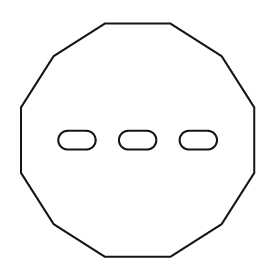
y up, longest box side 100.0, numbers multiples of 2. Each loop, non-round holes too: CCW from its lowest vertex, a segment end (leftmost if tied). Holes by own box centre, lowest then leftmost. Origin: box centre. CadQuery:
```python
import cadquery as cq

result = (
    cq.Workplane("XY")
    .moveTo(-14.0, -50.0)
    .lineTo(14.0, -50.0)
    .lineTo(36.0, -36.0)
    .lineTo(50.0, -14.0)
    .lineTo(50.0, 14.0)
    .lineTo(36.0, 36.0)
    .lineTo(14.0, 50.0)
    .lineTo(-14.0, 50.0)
    .lineTo(-36.0, 36.0)
    .lineTo(-50.0, 14.0)
    .lineTo(-50.0, -14.0)
    .lineTo(-36.0, -36.0)
    .close()
    .moveTo(-30.0, -4.0)
    .lineTo(-22.0, -4.0)
    .threePointArc((-18.0, 0.0), (-22.0, 4.0))
    .lineTo(-30.0, 4.0)
    .threePointArc((-34.0, 0.0), (-30.0, -4.0))
    .close()
    .moveTo(-4.0, -4.0)
    .lineTo(4.0, -4.0)
    .threePointArc((8.0, 0.0), (4.0, 4.0))
    .lineTo(-4.0, 4.0)
    .threePointArc((-8.0, 0.0), (-4.0, -4.0))
    .close()
    .moveTo(22.0, -4.0)
    .lineTo(30.0, -4.0)
    .threePointArc((34.0, 0.0), (30.0, 4.0))
    .lineTo(22.0, 4.0)
    .threePointArc((18.0, 0.0), (22.0, -4.0))
    .close()
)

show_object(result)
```